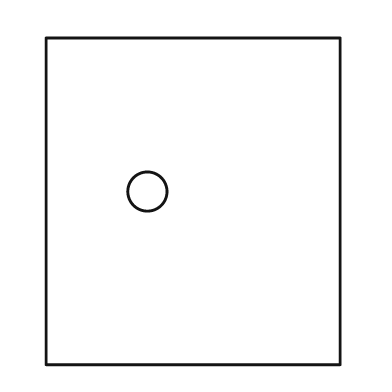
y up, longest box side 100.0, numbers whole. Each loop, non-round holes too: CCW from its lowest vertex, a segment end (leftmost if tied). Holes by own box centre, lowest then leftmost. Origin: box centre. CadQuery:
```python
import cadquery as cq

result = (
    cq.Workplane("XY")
    .moveTo(-45.0, -50.0)
    .lineTo(45.0, -50.0)
    .lineTo(45.0, 50.0)
    .lineTo(-45.0, 50.0)
    .close()
    .moveTo(-14.0, 3.0)
    .circle(6.0)
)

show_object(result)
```